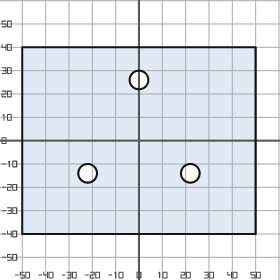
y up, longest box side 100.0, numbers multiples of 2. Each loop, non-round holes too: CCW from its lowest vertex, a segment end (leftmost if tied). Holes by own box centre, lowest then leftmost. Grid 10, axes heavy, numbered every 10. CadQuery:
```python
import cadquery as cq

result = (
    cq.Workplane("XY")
    .moveTo(-50.0, -40.0)
    .lineTo(50.0, -40.0)
    .lineTo(50.0, 40.0)
    .lineTo(-50.0, 40.0)
    .close()
    .moveTo(-22.0, -14.0)
    .circle(4.0)
    .moveTo(22.0, -14.0)
    .circle(4.0)
    .moveTo(0.0, 26.0)
    .circle(4.0)
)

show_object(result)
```